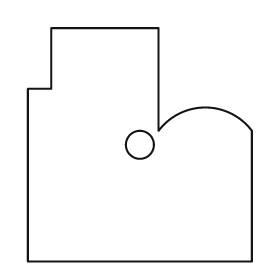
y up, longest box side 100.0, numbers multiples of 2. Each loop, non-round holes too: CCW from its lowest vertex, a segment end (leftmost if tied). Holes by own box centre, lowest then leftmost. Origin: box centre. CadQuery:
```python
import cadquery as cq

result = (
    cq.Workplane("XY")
    .moveTo(-48.0, -50.0)
    .lineTo(48.0, -50.0)
    .lineTo(48.0, 6.0)
    .threePointArc((28.0, 16.0), (8.0, 6.0))
    .lineTo(8.0, 50.0)
    .lineTo(-38.0, 50.0)
    .lineTo(-38.0, 24.0)
    .lineTo(-48.0, 24.0)
    .close()
    .moveTo(0.0, 0.0)
    .circle(6.0)
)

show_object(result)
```